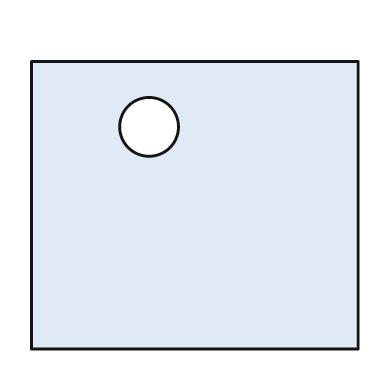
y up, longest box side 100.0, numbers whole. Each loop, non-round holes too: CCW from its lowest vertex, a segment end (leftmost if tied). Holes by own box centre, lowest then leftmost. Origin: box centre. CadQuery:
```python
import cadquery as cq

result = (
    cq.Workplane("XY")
    .moveTo(-50.0, -44.0)
    .lineTo(50.0, -44.0)
    .lineTo(50.0, 44.0)
    .lineTo(-50.0, 44.0)
    .close()
    .moveTo(-14.0, 24.0)
    .circle(9.0)
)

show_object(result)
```